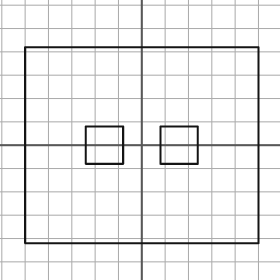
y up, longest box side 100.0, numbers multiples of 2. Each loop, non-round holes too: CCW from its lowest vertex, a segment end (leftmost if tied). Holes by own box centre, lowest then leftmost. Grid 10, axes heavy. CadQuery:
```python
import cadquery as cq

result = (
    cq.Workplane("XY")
    .moveTo(-50.0, -42.0)
    .lineTo(50.0, -42.0)
    .lineTo(50.0, 42.0)
    .lineTo(-50.0, 42.0)
    .close()
    .moveTo(-24.0, -8.0)
    .lineTo(-8.0, -8.0)
    .lineTo(-8.0, 8.0)
    .lineTo(-24.0, 8.0)
    .close()
    .moveTo(8.0, -8.0)
    .lineTo(24.0, -8.0)
    .lineTo(24.0, 8.0)
    .lineTo(8.0, 8.0)
    .close()
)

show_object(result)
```